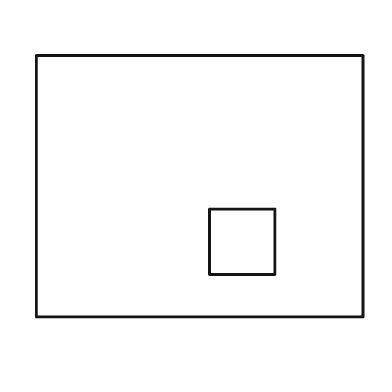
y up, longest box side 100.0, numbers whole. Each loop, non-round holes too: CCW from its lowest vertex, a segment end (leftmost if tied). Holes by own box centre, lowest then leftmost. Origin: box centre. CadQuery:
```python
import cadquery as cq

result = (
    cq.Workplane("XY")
    .moveTo(-50.0, -40.0)
    .lineTo(50.0, -40.0)
    .lineTo(50.0, 40.0)
    .lineTo(-50.0, 40.0)
    .close()
    .moveTo(3.0, -27.0)
    .lineTo(23.0, -27.0)
    .lineTo(23.0, -7.0)
    .lineTo(3.0, -7.0)
    .close()
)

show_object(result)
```